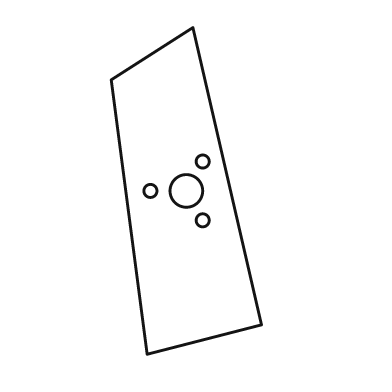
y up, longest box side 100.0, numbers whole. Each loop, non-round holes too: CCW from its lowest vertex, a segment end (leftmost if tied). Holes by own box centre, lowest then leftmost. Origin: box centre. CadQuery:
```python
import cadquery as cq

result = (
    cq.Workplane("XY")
    .moveTo(-12.0, -50.0)
    .lineTo(23.0, -41.0)
    .lineTo(2.0, 50.0)
    .lineTo(-23.0, 34.0)
    .close()
    .moveTo(5.0, -9.0)
    .circle(2.0)
    .moveTo(-11.0, 0.0)
    .circle(2.0)
    .moveTo(0.0, 0.0)
    .circle(5.0)
    .moveTo(5.0, 9.0)
    .circle(2.0)
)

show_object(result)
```